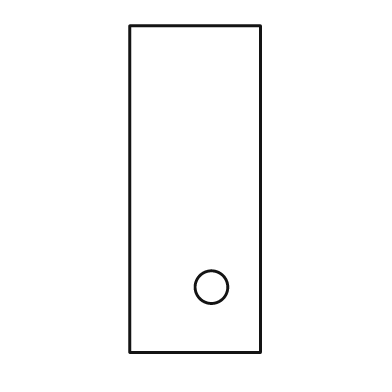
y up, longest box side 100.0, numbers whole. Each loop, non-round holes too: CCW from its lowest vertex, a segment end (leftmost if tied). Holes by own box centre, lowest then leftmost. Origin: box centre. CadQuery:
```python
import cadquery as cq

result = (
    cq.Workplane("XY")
    .moveTo(-20.0, -50.0)
    .lineTo(20.0, -50.0)
    .lineTo(20.0, 50.0)
    .lineTo(-20.0, 50.0)
    .close()
    .moveTo(5.0, -30.0)
    .circle(5.0)
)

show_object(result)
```